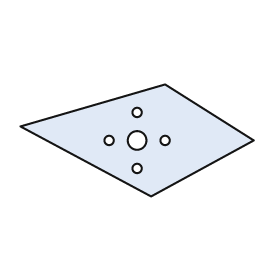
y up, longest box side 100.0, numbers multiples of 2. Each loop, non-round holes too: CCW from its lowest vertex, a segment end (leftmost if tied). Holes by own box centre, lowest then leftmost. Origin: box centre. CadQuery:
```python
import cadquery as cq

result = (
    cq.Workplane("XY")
    .moveTo(6.0, -24.0)
    .lineTo(50.0, 0.0)
    .lineTo(12.0, 24.0)
    .lineTo(-50.0, 6.0)
    .close()
    .moveTo(0.0, -12.0)
    .circle(2.0)
    .moveTo(-12.0, 0.0)
    .circle(2.0)
    .moveTo(0.0, 0.0)
    .circle(4.0)
    .moveTo(12.0, 0.0)
    .circle(2.0)
    .moveTo(0.0, 12.0)
    .circle(2.0)
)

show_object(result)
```